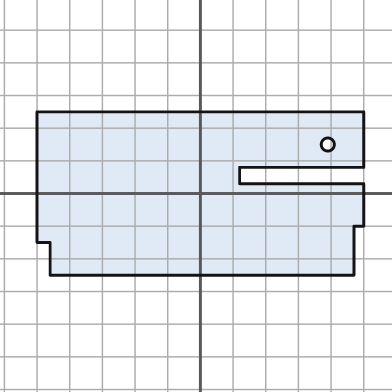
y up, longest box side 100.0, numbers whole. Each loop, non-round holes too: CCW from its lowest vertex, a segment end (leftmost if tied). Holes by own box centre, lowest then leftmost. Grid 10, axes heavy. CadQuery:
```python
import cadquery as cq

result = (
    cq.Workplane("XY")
    .moveTo(-46.0, -25.0)
    .lineTo(47.0, -25.0)
    .lineTo(47.0, -10.0)
    .lineTo(50.0, -10.0)
    .lineTo(50.0, 3.0)
    .lineTo(12.0, 3.0)
    .lineTo(12.0, 8.0)
    .lineTo(50.0, 8.0)
    .lineTo(50.0, 25.0)
    .lineTo(-50.0, 25.0)
    .lineTo(-50.0, -15.0)
    .lineTo(-46.0, -15.0)
    .close()
    .moveTo(39.0, 15.0)
    .circle(2.0)
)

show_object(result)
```